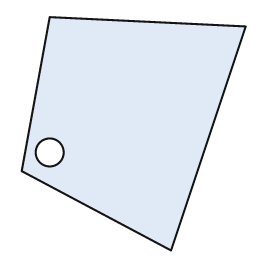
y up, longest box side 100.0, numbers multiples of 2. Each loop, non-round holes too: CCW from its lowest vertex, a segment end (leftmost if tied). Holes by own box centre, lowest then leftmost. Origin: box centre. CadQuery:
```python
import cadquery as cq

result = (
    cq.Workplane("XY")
    .moveTo(16.0, -50.0)
    .lineTo(48.0, 46.0)
    .lineTo(-36.0, 50.0)
    .lineTo(-48.0, -16.0)
    .close()
    .moveTo(-36.0, -8.0)
    .circle(6.0)
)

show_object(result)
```